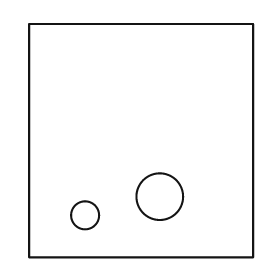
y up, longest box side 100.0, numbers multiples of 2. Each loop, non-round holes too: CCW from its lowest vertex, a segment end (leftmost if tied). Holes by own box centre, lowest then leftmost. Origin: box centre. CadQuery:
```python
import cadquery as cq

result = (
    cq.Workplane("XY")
    .moveTo(-48.0, -50.0)
    .lineTo(48.0, -50.0)
    .lineTo(48.0, 50.0)
    .lineTo(-48.0, 50.0)
    .close()
    .moveTo(-24.0, -32.0)
    .circle(6.0)
    .moveTo(8.0, -24.0)
    .circle(10.0)
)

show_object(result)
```